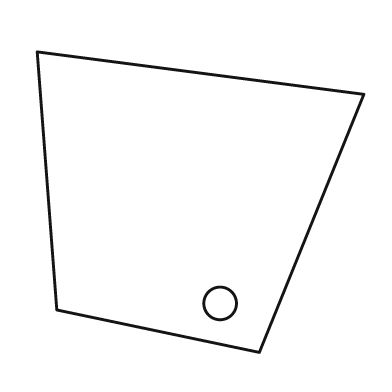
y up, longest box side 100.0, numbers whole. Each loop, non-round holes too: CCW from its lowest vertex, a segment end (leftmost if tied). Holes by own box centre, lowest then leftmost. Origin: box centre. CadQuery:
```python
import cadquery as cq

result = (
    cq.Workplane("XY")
    .moveTo(18.0, -46.0)
    .lineTo(50.0, 33.0)
    .lineTo(-50.0, 46.0)
    .lineTo(-44.0, -33.0)
    .close()
    .moveTo(6.0, -31.0)
    .circle(5.0)
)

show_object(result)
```